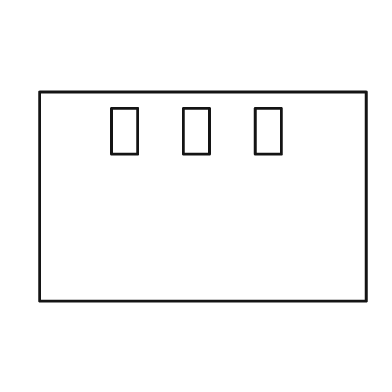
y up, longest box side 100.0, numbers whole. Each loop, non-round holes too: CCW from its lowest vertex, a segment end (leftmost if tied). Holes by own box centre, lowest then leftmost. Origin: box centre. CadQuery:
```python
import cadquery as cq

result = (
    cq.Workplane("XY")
    .moveTo(-50.0, -32.0)
    .lineTo(50.0, -32.0)
    .lineTo(50.0, 32.0)
    .lineTo(-50.0, 32.0)
    .close()
    .moveTo(-28.0, 13.0)
    .lineTo(-20.0, 13.0)
    .lineTo(-20.0, 27.0)
    .lineTo(-28.0, 27.0)
    .close()
    .moveTo(-6.0, 13.0)
    .lineTo(2.0, 13.0)
    .lineTo(2.0, 27.0)
    .lineTo(-6.0, 27.0)
    .close()
    .moveTo(16.0, 13.0)
    .lineTo(24.0, 13.0)
    .lineTo(24.0, 27.0)
    .lineTo(16.0, 27.0)
    .close()
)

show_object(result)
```